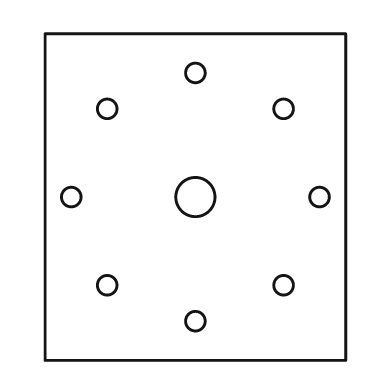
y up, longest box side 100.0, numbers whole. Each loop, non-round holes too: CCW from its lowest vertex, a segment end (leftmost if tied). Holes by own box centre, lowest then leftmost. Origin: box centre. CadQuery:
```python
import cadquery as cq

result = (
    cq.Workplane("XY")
    .moveTo(-46.0, -50.0)
    .lineTo(46.0, -50.0)
    .lineTo(46.0, 50.0)
    .lineTo(-46.0, 50.0)
    .close()
    .moveTo(0.0, -38.0)
    .circle(3.0)
    .moveTo(-27.0, -27.0)
    .circle(3.0)
    .moveTo(27.0, -27.0)
    .circle(3.0)
    .moveTo(-38.0, 0.0)
    .circle(3.0)
    .moveTo(0.0, 0.0)
    .circle(6.0)
    .moveTo(38.0, 0.0)
    .circle(3.0)
    .moveTo(-27.0, 27.0)
    .circle(3.0)
    .moveTo(27.0, 27.0)
    .circle(3.0)
    .moveTo(0.0, 38.0)
    .circle(3.0)
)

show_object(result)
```